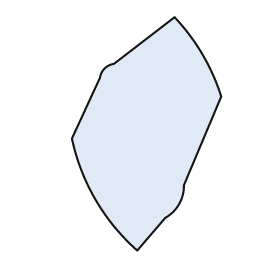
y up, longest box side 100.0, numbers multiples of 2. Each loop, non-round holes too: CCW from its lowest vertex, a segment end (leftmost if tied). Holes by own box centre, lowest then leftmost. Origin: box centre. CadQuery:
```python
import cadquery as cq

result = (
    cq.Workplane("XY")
    .moveTo(-4.0, -50.0)
    .lineTo(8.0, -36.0)
    .threePointArc((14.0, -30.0), (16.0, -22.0))
    .lineTo(32.0, 16.0)
    .threePointArc((24.0, 34.0), (12.0, 50.0))
    .lineTo(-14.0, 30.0)
    .threePointArc((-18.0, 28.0), (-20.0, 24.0))
    .lineTo(-32.0, -2.0)
    .threePointArc((-22.0, -28.0), (-4.0, -50.0))
    .close()
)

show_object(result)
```